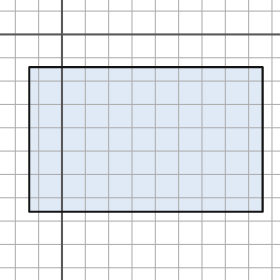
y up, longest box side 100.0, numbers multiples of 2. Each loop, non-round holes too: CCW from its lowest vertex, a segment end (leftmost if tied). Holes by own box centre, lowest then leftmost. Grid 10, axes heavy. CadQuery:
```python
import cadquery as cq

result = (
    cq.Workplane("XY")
    .moveTo(-14.0, -76.0)
    .lineTo(86.0, -76.0)
    .lineTo(86.0, -14.0)
    .lineTo(-14.0, -14.0)
    .close()
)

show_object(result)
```